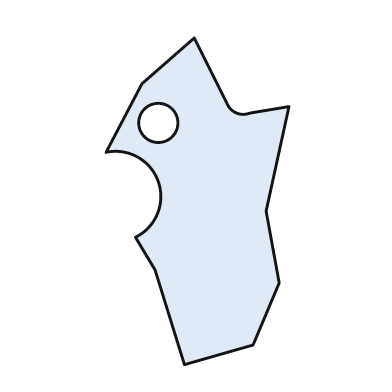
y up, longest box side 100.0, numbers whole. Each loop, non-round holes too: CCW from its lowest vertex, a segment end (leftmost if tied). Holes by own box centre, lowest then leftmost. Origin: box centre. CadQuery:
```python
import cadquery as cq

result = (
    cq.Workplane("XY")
    .moveTo(-4.0, -50.0)
    .lineTo(17.0, -44.0)
    .lineTo(25.0, -25.0)
    .lineTo(21.0, -3.0)
    .lineTo(28.0, 29.0)
    .lineTo(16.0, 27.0)
    .threePointArc((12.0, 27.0), (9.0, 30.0))
    .lineTo(-1.0, 50.0)
    .lineTo(-17.0, 36.0)
    .lineTo(-28.0, 15.0)
    .threePointArc((-12.0, 6.0), (-19.0, -11.0))
    .lineTo(-13.0, -21.0)
    .close()
    .moveTo(-12.0, 24.0)
    .circle(6.0)
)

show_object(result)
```